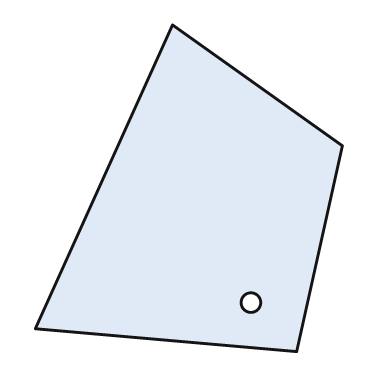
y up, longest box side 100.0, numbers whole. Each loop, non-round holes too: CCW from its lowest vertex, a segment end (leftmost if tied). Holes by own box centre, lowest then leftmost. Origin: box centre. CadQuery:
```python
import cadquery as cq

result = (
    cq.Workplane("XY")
    .moveTo(33.0, -50.0)
    .lineTo(47.0, 13.0)
    .lineTo(-5.0, 50.0)
    .lineTo(-47.0, -43.0)
    .close()
    .moveTo(19.0, -35.0)
    .circle(3.0)
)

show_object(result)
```